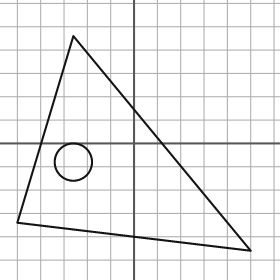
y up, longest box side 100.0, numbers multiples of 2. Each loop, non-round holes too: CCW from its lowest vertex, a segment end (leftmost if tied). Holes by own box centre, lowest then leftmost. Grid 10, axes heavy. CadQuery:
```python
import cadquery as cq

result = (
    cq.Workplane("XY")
    .moveTo(50.0, -46.0)
    .lineTo(-26.0, 46.0)
    .lineTo(-50.0, -34.0)
    .close()
    .moveTo(-26.0, -8.0)
    .circle(8.0)
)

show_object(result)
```